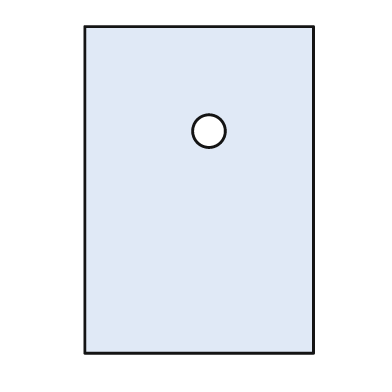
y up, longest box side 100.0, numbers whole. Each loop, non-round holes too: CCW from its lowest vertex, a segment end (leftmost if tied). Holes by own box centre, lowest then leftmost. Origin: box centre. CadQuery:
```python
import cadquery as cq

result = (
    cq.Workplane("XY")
    .moveTo(-35.0, -50.0)
    .lineTo(35.0, -50.0)
    .lineTo(35.0, 50.0)
    .lineTo(-35.0, 50.0)
    .close()
    .moveTo(3.0, 18.0)
    .circle(5.0)
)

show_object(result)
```